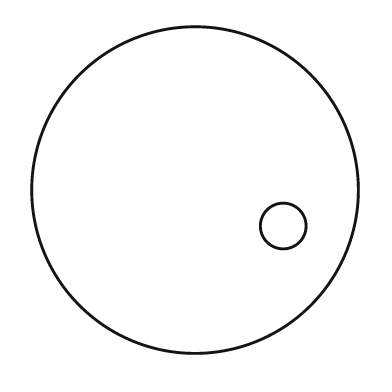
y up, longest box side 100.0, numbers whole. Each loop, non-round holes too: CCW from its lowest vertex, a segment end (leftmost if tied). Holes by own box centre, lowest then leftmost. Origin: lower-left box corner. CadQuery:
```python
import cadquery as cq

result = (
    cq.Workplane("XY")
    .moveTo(50.0, 50.0)
    .circle(50.0)
    .moveTo(77.0, 39.0)
    .circle(7.0)
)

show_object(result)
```